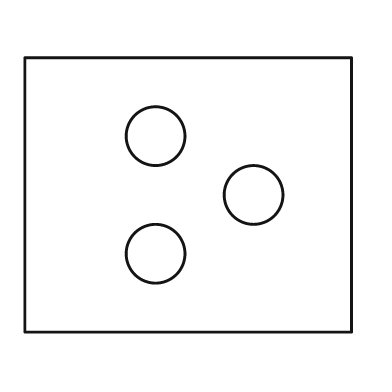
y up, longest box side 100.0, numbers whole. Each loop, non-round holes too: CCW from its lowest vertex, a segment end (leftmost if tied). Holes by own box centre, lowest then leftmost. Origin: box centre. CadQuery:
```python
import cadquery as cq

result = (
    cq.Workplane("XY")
    .moveTo(-50.0, -42.0)
    .lineTo(50.0, -42.0)
    .lineTo(50.0, 42.0)
    .lineTo(-50.0, 42.0)
    .close()
    .moveTo(-10.0, -18.0)
    .circle(9.0)
    .moveTo(20.0, 0.0)
    .circle(9.0)
    .moveTo(-10.0, 18.0)
    .circle(9.0)
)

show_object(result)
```